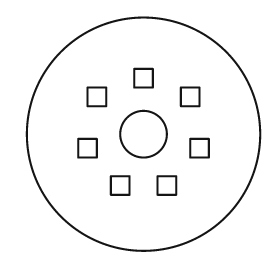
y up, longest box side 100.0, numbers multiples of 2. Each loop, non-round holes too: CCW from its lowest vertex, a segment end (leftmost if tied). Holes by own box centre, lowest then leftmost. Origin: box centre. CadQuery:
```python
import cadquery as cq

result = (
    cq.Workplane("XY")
    .moveTo(0.0, 0.0)
    .circle(50.0)
    .moveTo(-14.0, -26.0)
    .lineTo(-6.0, -26.0)
    .lineTo(-6.0, -18.0)
    .lineTo(-14.0, -18.0)
    .close()
    .moveTo(6.0, -26.0)
    .lineTo(14.0, -26.0)
    .lineTo(14.0, -18.0)
    .lineTo(6.0, -18.0)
    .close()
    .moveTo(-28.0, -10.0)
    .lineTo(-20.0, -10.0)
    .lineTo(-20.0, -2.0)
    .lineTo(-28.0, -2.0)
    .close()
    .moveTo(20.0, -10.0)
    .lineTo(28.0, -10.0)
    .lineTo(28.0, -2.0)
    .lineTo(20.0, -2.0)
    .close()
    .moveTo(0.0, 0.0)
    .circle(10.0)
    .moveTo(-24.0, 12.0)
    .lineTo(-16.0, 12.0)
    .lineTo(-16.0, 20.0)
    .lineTo(-24.0, 20.0)
    .close()
    .moveTo(16.0, 12.0)
    .lineTo(24.0, 12.0)
    .lineTo(24.0, 20.0)
    .lineTo(16.0, 20.0)
    .close()
    .moveTo(-4.0, 20.0)
    .lineTo(4.0, 20.0)
    .lineTo(4.0, 28.0)
    .lineTo(-4.0, 28.0)
    .close()
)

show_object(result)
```